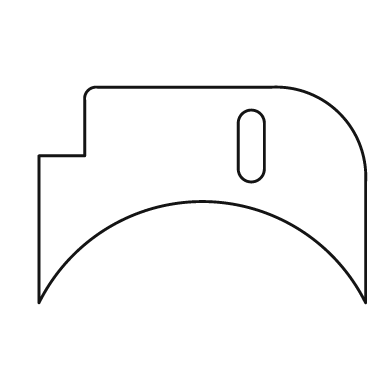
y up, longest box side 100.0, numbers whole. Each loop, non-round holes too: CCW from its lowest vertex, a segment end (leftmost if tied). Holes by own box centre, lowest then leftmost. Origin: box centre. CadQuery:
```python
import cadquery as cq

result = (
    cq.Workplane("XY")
    .moveTo(-50.0, -33.0)
    .threePointArc((0.0, -2.0), (50.0, -33.0))
    .lineTo(50.0, 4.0)
    .threePointArc((42.0, 25.0), (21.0, 33.0))
    .lineTo(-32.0, 33.0)
    .threePointArc((-35.0, 32.0), (-36.0, 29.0))
    .lineTo(-36.0, 12.0)
    .lineTo(-50.0, 12.0)
    .close()
    .moveTo(11.0, 8.0)
    .threePointArc((15.0, 4.0), (19.0, 8.0))
    .lineTo(19.0, 22.0)
    .threePointArc((15.0, 26.0), (11.0, 22.0))
    .close()
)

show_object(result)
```